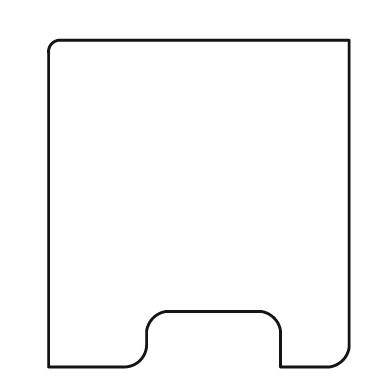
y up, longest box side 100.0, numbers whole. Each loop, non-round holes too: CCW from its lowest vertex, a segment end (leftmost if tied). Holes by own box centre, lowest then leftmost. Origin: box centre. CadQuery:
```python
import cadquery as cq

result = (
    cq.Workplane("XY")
    .moveTo(-46.0, -50.0)
    .lineTo(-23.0, -50.0)
    .threePointArc((-18.0, -48.0), (-16.0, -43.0))
    .lineTo(-16.0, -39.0)
    .threePointArc((-14.0, -35.0), (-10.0, -33.0))
    .lineTo(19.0, -33.0)
    .threePointArc((23.0, -35.0), (25.0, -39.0))
    .lineTo(25.0, -50.0)
    .lineTo(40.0, -50.0)
    .threePointArc((44.0, -48.0), (46.0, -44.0))
    .lineTo(46.0, 50.0)
    .lineTo(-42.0, 50.0)
    .threePointArc((-45.0, 49.0), (-46.0, 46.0))
    .close()
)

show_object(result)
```